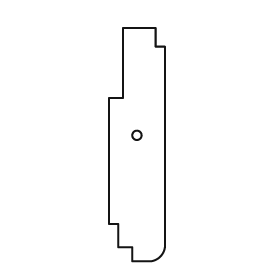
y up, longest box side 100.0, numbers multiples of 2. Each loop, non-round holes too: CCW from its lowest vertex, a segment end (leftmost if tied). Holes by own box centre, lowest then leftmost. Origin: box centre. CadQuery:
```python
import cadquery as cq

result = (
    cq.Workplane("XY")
    .moveTo(-2.0, -50.0)
    .lineTo(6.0, -50.0)
    .threePointArc((10.0, -48.0), (12.0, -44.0))
    .lineTo(12.0, 42.0)
    .lineTo(8.0, 42.0)
    .lineTo(8.0, 50.0)
    .lineTo(-6.0, 50.0)
    .lineTo(-6.0, 20.0)
    .lineTo(-12.0, 20.0)
    .lineTo(-12.0, -34.0)
    .lineTo(-8.0, -34.0)
    .lineTo(-8.0, -44.0)
    .lineTo(-2.0, -44.0)
    .close()
    .moveTo(0.0, 4.0)
    .circle(2.0)
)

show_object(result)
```